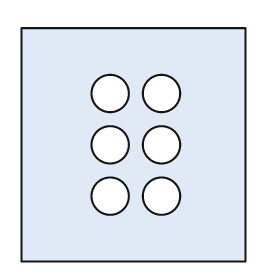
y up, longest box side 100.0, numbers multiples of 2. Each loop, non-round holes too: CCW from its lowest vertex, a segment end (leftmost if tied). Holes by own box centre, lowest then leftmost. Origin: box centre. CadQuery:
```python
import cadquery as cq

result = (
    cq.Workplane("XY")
    .moveTo(-48.0, -50.0)
    .lineTo(48.0, -50.0)
    .lineTo(48.0, 50.0)
    .lineTo(-48.0, 50.0)
    .close()
    .moveTo(-10.0, -22.0)
    .circle(8.0)
    .moveTo(12.0, -22.0)
    .circle(8.0)
    .moveTo(-10.0, 0.0)
    .circle(8.0)
    .moveTo(12.0, 0.0)
    .circle(8.0)
    .moveTo(-10.0, 22.0)
    .circle(8.0)
    .moveTo(12.0, 22.0)
    .circle(8.0)
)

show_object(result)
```